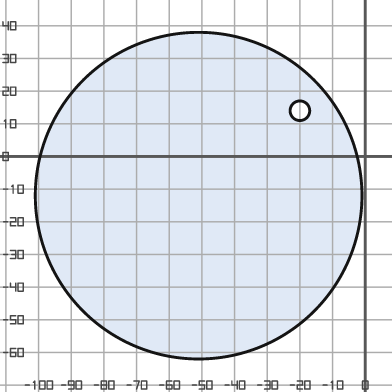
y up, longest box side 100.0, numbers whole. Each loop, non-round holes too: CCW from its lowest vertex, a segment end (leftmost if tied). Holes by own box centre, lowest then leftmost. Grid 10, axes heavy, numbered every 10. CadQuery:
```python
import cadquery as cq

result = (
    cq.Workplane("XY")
    .moveTo(-51.0, -12.0)
    .circle(50.0)
    .moveTo(-20.0, 14.0)
    .circle(3.0)
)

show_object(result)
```